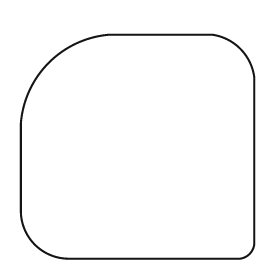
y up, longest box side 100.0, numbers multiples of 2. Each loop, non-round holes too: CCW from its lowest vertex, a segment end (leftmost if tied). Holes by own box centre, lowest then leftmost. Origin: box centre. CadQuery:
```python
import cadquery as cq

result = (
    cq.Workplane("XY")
    .moveTo(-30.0, -48.0)
    .lineTo(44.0, -48.0)
    .threePointArc((48.0, -46.0), (50.0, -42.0))
    .lineTo(50.0, 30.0)
    .threePointArc((44.0, 42.0), (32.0, 48.0))
    .lineTo(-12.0, 48.0)
    .threePointArc((-38.0, 36.0), (-50.0, 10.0))
    .lineTo(-50.0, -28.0)
    .threePointArc((-44.0, -42.0), (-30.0, -48.0))
    .close()
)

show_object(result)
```